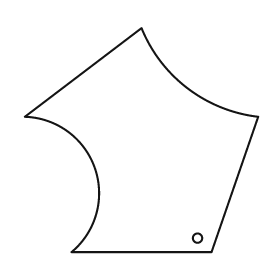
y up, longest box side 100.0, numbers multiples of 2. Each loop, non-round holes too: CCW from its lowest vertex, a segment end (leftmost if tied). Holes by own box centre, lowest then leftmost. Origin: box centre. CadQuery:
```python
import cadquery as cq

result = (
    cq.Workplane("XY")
    .moveTo(-30.0, -48.0)
    .lineTo(30.0, -48.0)
    .lineTo(50.0, 10.0)
    .threePointArc((20.0, 22.0), (0.0, 48.0))
    .lineTo(-50.0, 10.0)
    .threePointArc((-20.0, -12.0), (-30.0, -48.0))
    .close()
    .moveTo(24.0, -42.0)
    .circle(2.0)
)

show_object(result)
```